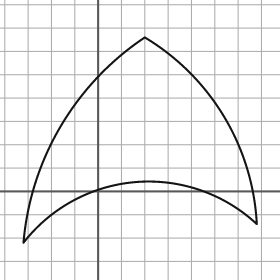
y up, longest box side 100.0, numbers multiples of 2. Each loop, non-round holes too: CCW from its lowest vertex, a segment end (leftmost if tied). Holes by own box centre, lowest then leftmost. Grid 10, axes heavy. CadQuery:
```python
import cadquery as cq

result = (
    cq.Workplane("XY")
    .moveTo(-32.0, -22.0)
    .threePointArc((16.0, 4.0), (68.0, -14.0))
    .threePointArc((54.0, 32.0), (20.0, 66.0))
    .threePointArc((-16.0, 28.0), (-32.0, -22.0))
    .close()
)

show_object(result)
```